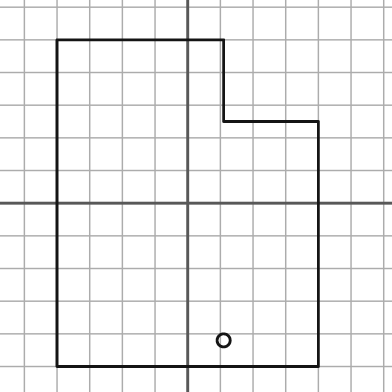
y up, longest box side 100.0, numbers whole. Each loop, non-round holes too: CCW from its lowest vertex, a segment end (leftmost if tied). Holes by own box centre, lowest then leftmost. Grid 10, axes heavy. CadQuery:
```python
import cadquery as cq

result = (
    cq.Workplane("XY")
    .moveTo(-40.0, -50.0)
    .lineTo(40.0, -50.0)
    .lineTo(40.0, 25.0)
    .lineTo(11.0, 25.0)
    .lineTo(11.0, 50.0)
    .lineTo(-40.0, 50.0)
    .close()
    .moveTo(11.0, -42.0)
    .circle(2.0)
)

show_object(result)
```